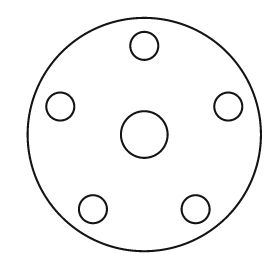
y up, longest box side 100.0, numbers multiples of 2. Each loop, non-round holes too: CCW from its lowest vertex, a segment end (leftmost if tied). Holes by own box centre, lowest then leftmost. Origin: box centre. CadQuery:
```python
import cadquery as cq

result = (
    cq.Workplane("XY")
    .moveTo(0.0, 0.0)
    .circle(50.0)
    .moveTo(-22.0, -32.0)
    .circle(6.0)
    .moveTo(22.0, -32.0)
    .circle(6.0)
    .moveTo(0.0, 0.0)
    .circle(10.0)
    .moveTo(-36.0, 12.0)
    .circle(6.0)
    .moveTo(36.0, 12.0)
    .circle(6.0)
    .moveTo(0.0, 38.0)
    .circle(6.0)
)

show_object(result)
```